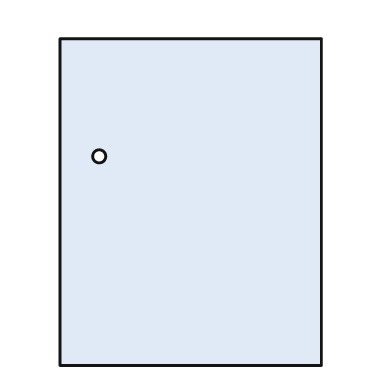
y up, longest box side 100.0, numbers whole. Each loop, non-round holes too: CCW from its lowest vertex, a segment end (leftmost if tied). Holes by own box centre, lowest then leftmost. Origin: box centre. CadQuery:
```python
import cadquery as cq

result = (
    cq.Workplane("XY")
    .moveTo(-40.0, -50.0)
    .lineTo(40.0, -50.0)
    .lineTo(40.0, 50.0)
    .lineTo(-40.0, 50.0)
    .close()
    .moveTo(-28.0, 14.0)
    .circle(2.0)
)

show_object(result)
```